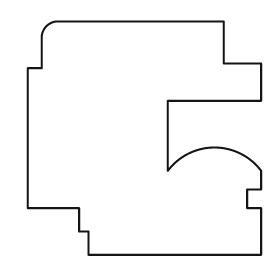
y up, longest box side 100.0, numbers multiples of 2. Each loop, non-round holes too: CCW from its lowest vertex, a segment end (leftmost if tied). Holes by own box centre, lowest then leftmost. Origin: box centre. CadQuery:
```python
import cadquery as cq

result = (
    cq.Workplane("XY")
    .moveTo(-24.0, -50.0)
    .lineTo(50.0, -50.0)
    .lineTo(50.0, -30.0)
    .lineTo(44.0, -30.0)
    .lineTo(44.0, -22.0)
    .lineTo(50.0, -22.0)
    .lineTo(50.0, -14.0)
    .threePointArc((30.0, -4.0), (10.0, -14.0))
    .lineTo(10.0, 16.0)
    .lineTo(50.0, 16.0)
    .lineTo(50.0, 32.0)
    .lineTo(34.0, 32.0)
    .lineTo(34.0, 50.0)
    .lineTo(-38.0, 50.0)
    .threePointArc((-42.0, 48.0), (-44.0, 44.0))
    .lineTo(-44.0, 30.0)
    .lineTo(-50.0, 30.0)
    .lineTo(-50.0, -30.0)
    .lineTo(-28.0, -30.0)
    .lineTo(-28.0, -40.0)
    .lineTo(-24.0, -40.0)
    .close()
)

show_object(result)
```